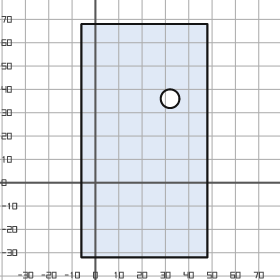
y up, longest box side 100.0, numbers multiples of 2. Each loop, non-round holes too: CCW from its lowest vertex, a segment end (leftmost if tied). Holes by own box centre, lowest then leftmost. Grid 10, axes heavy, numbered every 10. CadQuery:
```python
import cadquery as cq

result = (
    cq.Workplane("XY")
    .moveTo(-6.0, -32.0)
    .lineTo(48.0, -32.0)
    .lineTo(48.0, 68.0)
    .lineTo(-6.0, 68.0)
    .close()
    .moveTo(32.0, 36.0)
    .circle(4.0)
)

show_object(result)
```